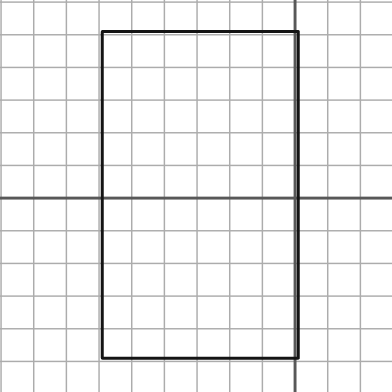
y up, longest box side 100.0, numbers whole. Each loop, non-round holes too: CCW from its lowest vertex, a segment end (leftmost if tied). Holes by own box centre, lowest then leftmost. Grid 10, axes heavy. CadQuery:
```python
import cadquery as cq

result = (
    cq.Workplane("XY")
    .moveTo(-59.0, -49.0)
    .lineTo(1.0, -49.0)
    .lineTo(1.0, 51.0)
    .lineTo(-59.0, 51.0)
    .close()
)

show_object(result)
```